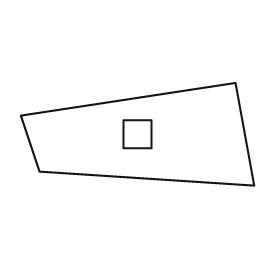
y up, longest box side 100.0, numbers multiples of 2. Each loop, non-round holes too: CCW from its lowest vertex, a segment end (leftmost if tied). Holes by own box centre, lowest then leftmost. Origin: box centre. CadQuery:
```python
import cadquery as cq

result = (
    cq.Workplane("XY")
    .moveTo(50.0, -22.0)
    .lineTo(42.0, 22.0)
    .lineTo(-50.0, 8.0)
    .lineTo(-42.0, -16.0)
    .close()
    .moveTo(-6.0, -6.0)
    .lineTo(6.0, -6.0)
    .lineTo(6.0, 6.0)
    .lineTo(-6.0, 6.0)
    .close()
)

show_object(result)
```